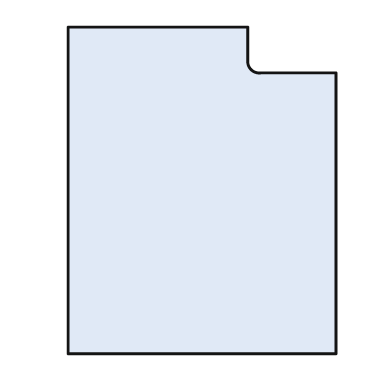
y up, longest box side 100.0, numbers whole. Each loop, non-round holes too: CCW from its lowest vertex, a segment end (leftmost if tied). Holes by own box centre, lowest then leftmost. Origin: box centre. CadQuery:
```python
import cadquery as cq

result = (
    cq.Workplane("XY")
    .moveTo(-41.0, -50.0)
    .lineTo(41.0, -50.0)
    .lineTo(41.0, 36.0)
    .lineTo(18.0, 36.0)
    .threePointArc((15.0, 37.0), (14.0, 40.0))
    .lineTo(14.0, 50.0)
    .lineTo(-41.0, 50.0)
    .close()
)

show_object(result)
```